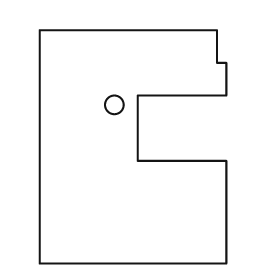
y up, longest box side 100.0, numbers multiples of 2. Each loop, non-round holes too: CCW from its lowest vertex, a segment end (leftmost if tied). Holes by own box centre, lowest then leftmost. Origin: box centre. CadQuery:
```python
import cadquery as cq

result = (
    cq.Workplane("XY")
    .moveTo(-40.0, -50.0)
    .lineTo(40.0, -50.0)
    .lineTo(40.0, -6.0)
    .lineTo(2.0, -6.0)
    .lineTo(2.0, 22.0)
    .lineTo(40.0, 22.0)
    .lineTo(40.0, 36.0)
    .lineTo(36.0, 36.0)
    .lineTo(36.0, 50.0)
    .lineTo(-40.0, 50.0)
    .close()
    .moveTo(-8.0, 18.0)
    .circle(4.0)
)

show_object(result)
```